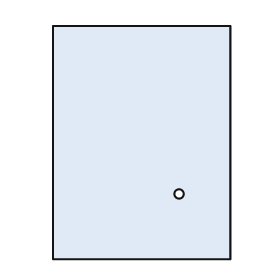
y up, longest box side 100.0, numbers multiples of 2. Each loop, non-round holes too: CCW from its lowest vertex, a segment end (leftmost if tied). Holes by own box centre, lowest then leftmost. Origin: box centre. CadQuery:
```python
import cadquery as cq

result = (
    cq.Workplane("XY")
    .moveTo(-38.0, -50.0)
    .lineTo(38.0, -50.0)
    .lineTo(38.0, 50.0)
    .lineTo(-38.0, 50.0)
    .close()
    .moveTo(16.0, -22.0)
    .circle(2.0)
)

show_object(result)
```